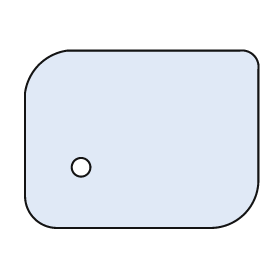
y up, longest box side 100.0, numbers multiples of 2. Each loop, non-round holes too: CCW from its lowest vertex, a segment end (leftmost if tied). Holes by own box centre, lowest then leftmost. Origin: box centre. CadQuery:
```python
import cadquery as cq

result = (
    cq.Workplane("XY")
    .moveTo(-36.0, -38.0)
    .lineTo(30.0, -38.0)
    .threePointArc((44.0, -32.0), (50.0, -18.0))
    .lineTo(50.0, 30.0)
    .threePointArc((48.0, 36.0), (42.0, 38.0))
    .lineTo(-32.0, 38.0)
    .threePointArc((-44.0, 32.0), (-50.0, 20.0))
    .lineTo(-50.0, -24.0)
    .threePointArc((-46.0, -34.0), (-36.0, -38.0))
    .close()
    .moveTo(-26.0, -12.0)
    .circle(4.0)
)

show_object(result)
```